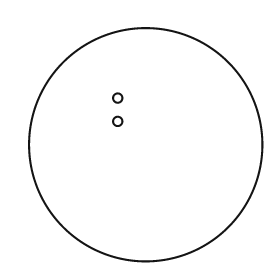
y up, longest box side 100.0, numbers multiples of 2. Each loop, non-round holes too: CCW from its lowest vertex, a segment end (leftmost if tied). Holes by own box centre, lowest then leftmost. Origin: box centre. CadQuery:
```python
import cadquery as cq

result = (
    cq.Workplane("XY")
    .moveTo(0.0, 0.0)
    .circle(50.0)
    .moveTo(-12.0, 10.0)
    .circle(2.0)
    .moveTo(-12.0, 20.0)
    .circle(2.0)
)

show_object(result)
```